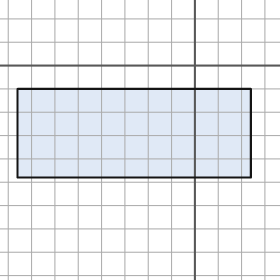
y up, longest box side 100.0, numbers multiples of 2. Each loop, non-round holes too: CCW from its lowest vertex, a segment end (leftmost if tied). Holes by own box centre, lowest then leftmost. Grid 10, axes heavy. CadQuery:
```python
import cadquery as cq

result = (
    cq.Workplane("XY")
    .moveTo(-76.0, -48.0)
    .lineTo(24.0, -48.0)
    .lineTo(24.0, -10.0)
    .lineTo(-76.0, -10.0)
    .close()
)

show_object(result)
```